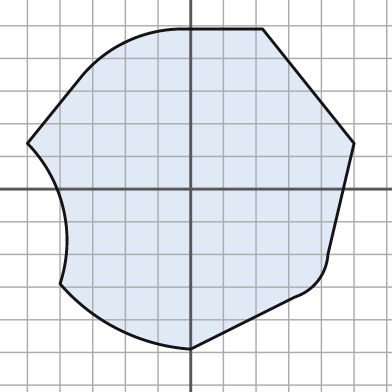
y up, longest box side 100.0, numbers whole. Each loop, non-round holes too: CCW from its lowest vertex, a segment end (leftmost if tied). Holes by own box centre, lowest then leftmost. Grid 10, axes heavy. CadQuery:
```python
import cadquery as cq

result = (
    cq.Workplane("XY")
    .moveTo(0.0, -49.0)
    .lineTo(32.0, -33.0)
    .threePointArc((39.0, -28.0), (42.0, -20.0))
    .lineTo(50.0, 14.0)
    .lineTo(22.0, 49.0)
    .lineTo(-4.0, 49.0)
    .threePointArc((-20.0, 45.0), (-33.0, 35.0))
    .lineTo(-50.0, 14.0)
    .threePointArc((-39.0, -6.0), (-40.0, -29.0))
    .threePointArc((-22.0, -43.0), (0.0, -49.0))
    .close()
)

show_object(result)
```